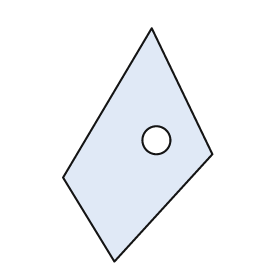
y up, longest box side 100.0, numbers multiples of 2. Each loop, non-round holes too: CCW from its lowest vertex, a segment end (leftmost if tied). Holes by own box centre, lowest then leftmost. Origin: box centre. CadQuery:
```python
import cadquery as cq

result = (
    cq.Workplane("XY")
    .moveTo(-10.0, -50.0)
    .lineTo(32.0, -4.0)
    .lineTo(6.0, 50.0)
    .lineTo(-32.0, -14.0)
    .close()
    .moveTo(8.0, 2.0)
    .circle(6.0)
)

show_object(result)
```